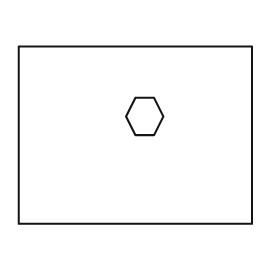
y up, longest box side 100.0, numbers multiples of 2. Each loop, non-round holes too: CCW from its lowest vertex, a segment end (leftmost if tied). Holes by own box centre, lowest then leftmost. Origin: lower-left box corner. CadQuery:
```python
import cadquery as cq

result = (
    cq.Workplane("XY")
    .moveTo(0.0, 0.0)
    .lineTo(100.0, 0.0)
    .lineTo(100.0, 76.0)
    .lineTo(0.0, 76.0)
    .close()
    .moveTo(50.0, 38.0)
    .lineTo(58.0, 38.0)
    .lineTo(62.0, 46.0)
    .lineTo(58.0, 54.0)
    .lineTo(50.0, 54.0)
    .lineTo(46.0, 46.0)
    .close()
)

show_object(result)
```